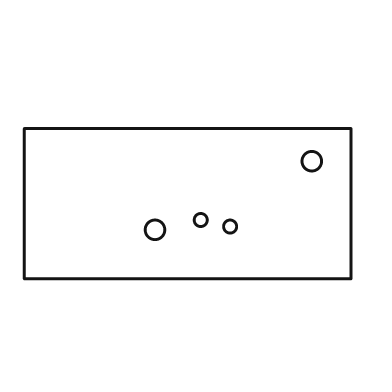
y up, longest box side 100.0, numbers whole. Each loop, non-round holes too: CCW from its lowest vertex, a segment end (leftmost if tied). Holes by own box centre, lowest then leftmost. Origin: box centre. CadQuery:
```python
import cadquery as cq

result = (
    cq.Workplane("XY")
    .moveTo(-50.0, -23.0)
    .lineTo(50.0, -23.0)
    .lineTo(50.0, 23.0)
    .lineTo(-50.0, 23.0)
    .close()
    .moveTo(-10.0, -8.0)
    .circle(3.0)
    .moveTo(13.0, -7.0)
    .circle(2.0)
    .moveTo(4.0, -5.0)
    .circle(2.0)
    .moveTo(38.0, 13.0)
    .circle(3.0)
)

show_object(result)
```